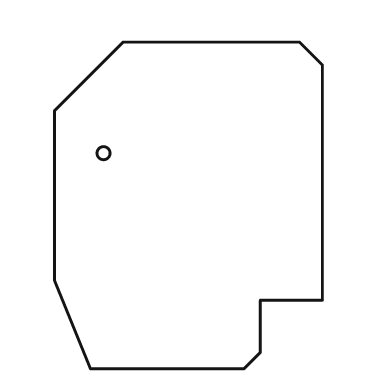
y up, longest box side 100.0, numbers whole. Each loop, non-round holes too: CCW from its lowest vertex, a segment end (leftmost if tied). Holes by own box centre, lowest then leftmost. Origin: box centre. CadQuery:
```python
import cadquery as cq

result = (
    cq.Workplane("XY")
    .moveTo(-30.0, -50.0)
    .lineTo(17.0, -50.0)
    .lineTo(22.0, -45.0)
    .lineTo(22.0, -29.0)
    .lineTo(41.0, -29.0)
    .lineTo(41.0, 43.0)
    .lineTo(34.0, 50.0)
    .lineTo(-20.0, 50.0)
    .lineTo(-41.0, 29.0)
    .lineTo(-41.0, -23.0)
    .close()
    .moveTo(-26.0, 16.0)
    .circle(2.0)
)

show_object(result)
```